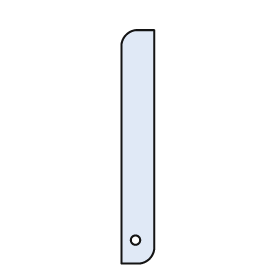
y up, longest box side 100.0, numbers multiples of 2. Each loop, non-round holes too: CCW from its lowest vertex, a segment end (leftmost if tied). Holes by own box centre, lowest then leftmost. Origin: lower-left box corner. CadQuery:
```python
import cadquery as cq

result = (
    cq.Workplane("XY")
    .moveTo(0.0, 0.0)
    .lineTo(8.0, 0.0)
    .threePointArc((12.0, 2.0), (14.0, 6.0))
    .lineTo(14.0, 100.0)
    .lineTo(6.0, 100.0)
    .threePointArc((2.0, 98.0), (0.0, 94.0))
    .close()
    .moveTo(6.0, 10.0)
    .circle(2.0)
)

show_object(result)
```